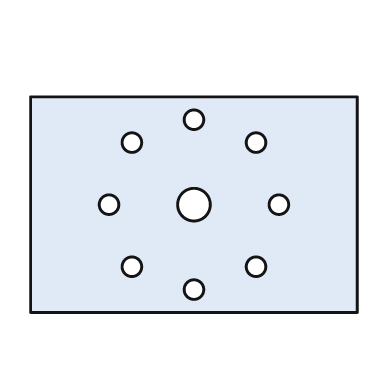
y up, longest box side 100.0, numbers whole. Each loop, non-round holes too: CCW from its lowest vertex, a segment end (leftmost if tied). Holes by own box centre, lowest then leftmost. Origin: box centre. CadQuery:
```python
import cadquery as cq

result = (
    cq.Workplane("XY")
    .moveTo(-50.0, -33.0)
    .lineTo(50.0, -33.0)
    .lineTo(50.0, 33.0)
    .lineTo(-50.0, 33.0)
    .close()
    .moveTo(0.0, -26.0)
    .circle(3.0)
    .moveTo(-19.0, -19.0)
    .circle(3.0)
    .moveTo(19.0, -19.0)
    .circle(3.0)
    .moveTo(-26.0, 0.0)
    .circle(3.0)
    .moveTo(0.0, 0.0)
    .circle(5.0)
    .moveTo(26.0, 0.0)
    .circle(3.0)
    .moveTo(-19.0, 19.0)
    .circle(3.0)
    .moveTo(19.0, 19.0)
    .circle(3.0)
    .moveTo(0.0, 26.0)
    .circle(3.0)
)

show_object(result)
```